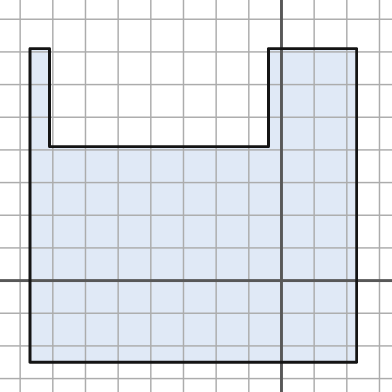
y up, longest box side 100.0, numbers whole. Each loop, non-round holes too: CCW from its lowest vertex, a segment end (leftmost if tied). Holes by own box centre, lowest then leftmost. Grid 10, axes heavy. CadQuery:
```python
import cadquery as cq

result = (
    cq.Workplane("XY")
    .moveTo(-77.0, -25.0)
    .lineTo(23.0, -25.0)
    .lineTo(23.0, 71.0)
    .lineTo(-4.0, 71.0)
    .lineTo(-4.0, 41.0)
    .lineTo(-71.0, 41.0)
    .lineTo(-71.0, 71.0)
    .lineTo(-77.0, 71.0)
    .close()
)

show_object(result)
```